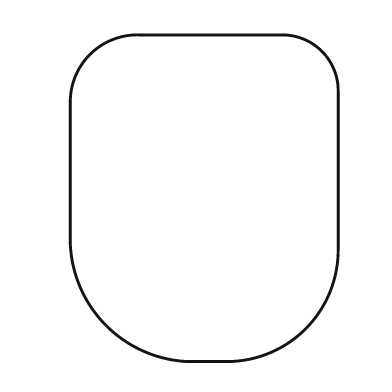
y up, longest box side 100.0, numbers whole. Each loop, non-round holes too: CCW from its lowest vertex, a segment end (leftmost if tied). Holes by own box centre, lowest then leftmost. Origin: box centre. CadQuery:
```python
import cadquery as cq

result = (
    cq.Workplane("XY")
    .moveTo(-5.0, -50.0)
    .lineTo(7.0, -50.0)
    .threePointArc((31.0, -40.0), (41.0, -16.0))
    .lineTo(41.0, 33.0)
    .threePointArc((36.0, 45.0), (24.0, 50.0))
    .lineTo(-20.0, 50.0)
    .threePointArc((-35.0, 44.0), (-41.0, 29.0))
    .lineTo(-41.0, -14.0)
    .threePointArc((-30.0, -39.0), (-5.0, -50.0))
    .close()
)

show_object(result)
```